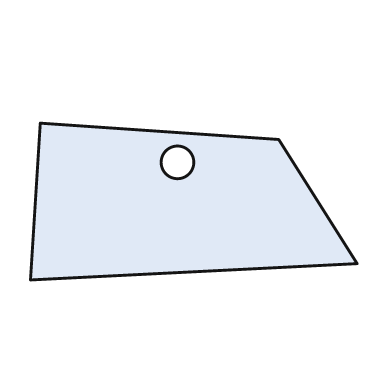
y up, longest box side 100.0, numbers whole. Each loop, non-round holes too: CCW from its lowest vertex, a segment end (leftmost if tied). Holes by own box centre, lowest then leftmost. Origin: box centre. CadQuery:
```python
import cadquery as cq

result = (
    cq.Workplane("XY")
    .moveTo(-50.0, -24.0)
    .lineTo(50.0, -19.0)
    .lineTo(26.0, 19.0)
    .lineTo(-47.0, 24.0)
    .close()
    .moveTo(-5.0, 12.0)
    .circle(5.0)
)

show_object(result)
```